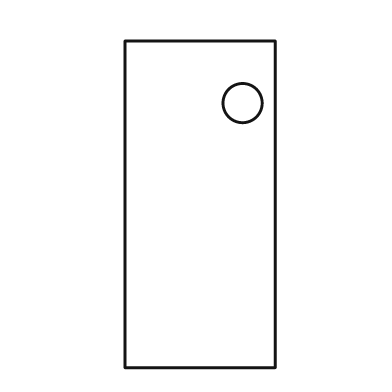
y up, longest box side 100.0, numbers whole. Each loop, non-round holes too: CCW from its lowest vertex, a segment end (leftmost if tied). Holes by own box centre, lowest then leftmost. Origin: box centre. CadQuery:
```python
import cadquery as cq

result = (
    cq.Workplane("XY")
    .moveTo(-23.0, -50.0)
    .lineTo(23.0, -50.0)
    .lineTo(23.0, 50.0)
    .lineTo(-23.0, 50.0)
    .close()
    .moveTo(13.0, 31.0)
    .circle(6.0)
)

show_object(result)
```